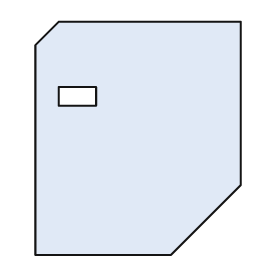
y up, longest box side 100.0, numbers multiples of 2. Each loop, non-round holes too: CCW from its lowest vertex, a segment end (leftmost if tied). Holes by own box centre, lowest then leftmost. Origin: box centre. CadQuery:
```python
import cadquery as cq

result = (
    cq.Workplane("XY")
    .moveTo(-44.0, -50.0)
    .lineTo(14.0, -50.0)
    .lineTo(44.0, -20.0)
    .lineTo(44.0, 50.0)
    .lineTo(-34.0, 50.0)
    .lineTo(-44.0, 40.0)
    .close()
    .moveTo(-34.0, 14.0)
    .lineTo(-18.0, 14.0)
    .lineTo(-18.0, 22.0)
    .lineTo(-34.0, 22.0)
    .close()
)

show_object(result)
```